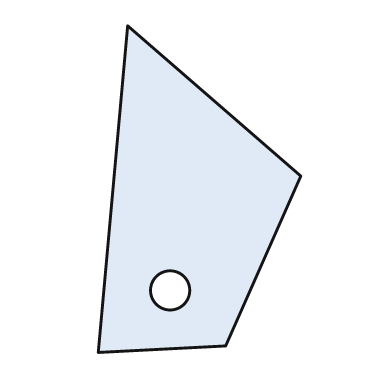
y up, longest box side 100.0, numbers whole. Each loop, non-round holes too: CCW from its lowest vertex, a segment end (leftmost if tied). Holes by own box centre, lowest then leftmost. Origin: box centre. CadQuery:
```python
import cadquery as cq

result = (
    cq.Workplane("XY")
    .moveTo(-31.0, -50.0)
    .lineTo(8.0, -48.0)
    .lineTo(31.0, 4.0)
    .lineTo(-22.0, 50.0)
    .close()
    .moveTo(-9.0, -31.0)
    .circle(6.0)
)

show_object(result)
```